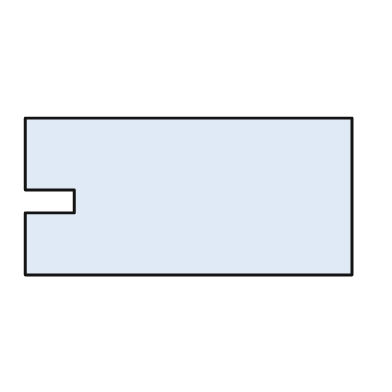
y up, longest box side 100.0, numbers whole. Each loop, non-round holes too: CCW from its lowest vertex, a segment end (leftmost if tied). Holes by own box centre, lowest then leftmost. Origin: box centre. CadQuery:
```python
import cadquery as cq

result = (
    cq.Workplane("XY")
    .moveTo(-50.0, -24.0)
    .lineTo(50.0, -24.0)
    .lineTo(50.0, 24.0)
    .lineTo(-50.0, 24.0)
    .lineTo(-50.0, 2.0)
    .lineTo(-35.0, 2.0)
    .lineTo(-35.0, -5.0)
    .lineTo(-50.0, -5.0)
    .close()
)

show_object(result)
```